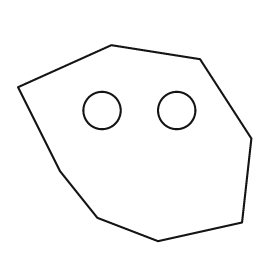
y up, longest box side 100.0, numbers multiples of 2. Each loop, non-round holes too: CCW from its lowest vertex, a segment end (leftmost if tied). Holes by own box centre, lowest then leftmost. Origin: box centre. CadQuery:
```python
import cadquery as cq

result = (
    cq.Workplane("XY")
    .moveTo(10.0, -42.0)
    .lineTo(46.0, -34.0)
    .lineTo(50.0, 2.0)
    .lineTo(28.0, 36.0)
    .lineTo(-10.0, 42.0)
    .lineTo(-50.0, 24.0)
    .lineTo(-32.0, -12.0)
    .lineTo(-16.0, -32.0)
    .close()
    .moveTo(-14.0, 14.0)
    .circle(8.0)
    .moveTo(18.0, 14.0)
    .circle(8.0)
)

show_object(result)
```